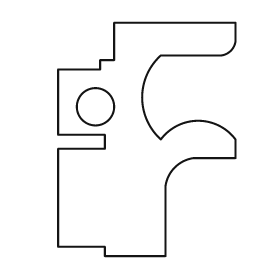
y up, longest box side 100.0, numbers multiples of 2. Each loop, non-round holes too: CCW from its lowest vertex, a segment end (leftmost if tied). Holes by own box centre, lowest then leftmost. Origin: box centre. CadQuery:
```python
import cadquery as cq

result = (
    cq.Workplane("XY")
    .moveTo(-18.0, -50.0)
    .lineTo(8.0, -50.0)
    .lineTo(8.0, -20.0)
    .threePointArc((12.0, -12.0), (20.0, -8.0))
    .lineTo(38.0, -8.0)
    .lineTo(38.0, 0.0)
    .threePointArc((22.0, 8.0), (6.0, 0.0))
    .threePointArc((-2.0, 18.0), (6.0, 36.0))
    .lineTo(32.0, 36.0)
    .threePointArc((36.0, 38.0), (38.0, 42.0))
    .lineTo(38.0, 50.0)
    .lineTo(-14.0, 50.0)
    .lineTo(-14.0, 34.0)
    .lineTo(-20.0, 34.0)
    .lineTo(-20.0, 30.0)
    .lineTo(-38.0, 30.0)
    .lineTo(-38.0, 2.0)
    .lineTo(-18.0, 2.0)
    .lineTo(-18.0, -4.0)
    .lineTo(-38.0, -4.0)
    .lineTo(-38.0, -46.0)
    .lineTo(-18.0, -46.0)
    .close()
    .moveTo(-22.0, 14.0)
    .circle(8.0)
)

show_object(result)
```